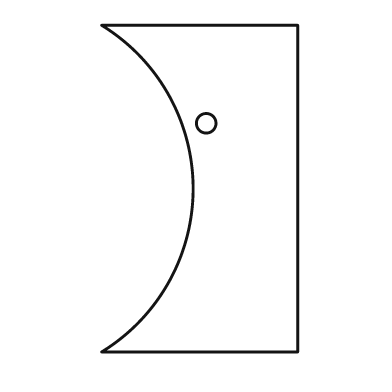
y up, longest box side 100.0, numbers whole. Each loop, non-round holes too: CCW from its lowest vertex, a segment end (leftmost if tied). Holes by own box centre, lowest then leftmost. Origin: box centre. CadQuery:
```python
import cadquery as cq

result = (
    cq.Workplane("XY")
    .moveTo(-30.0, -50.0)
    .lineTo(30.0, -50.0)
    .lineTo(30.0, 50.0)
    .lineTo(-30.0, 50.0)
    .threePointArc((-2.0, 0.0), (-30.0, -50.0))
    .close()
    .moveTo(2.0, 20.0)
    .circle(3.0)
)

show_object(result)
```